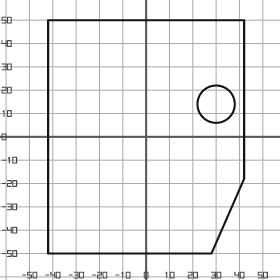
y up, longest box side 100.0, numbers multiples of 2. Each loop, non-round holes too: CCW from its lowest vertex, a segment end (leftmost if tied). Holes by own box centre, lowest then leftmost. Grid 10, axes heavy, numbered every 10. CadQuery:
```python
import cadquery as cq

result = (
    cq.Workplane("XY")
    .moveTo(-42.0, -50.0)
    .lineTo(28.0, -50.0)
    .lineTo(42.0, -18.0)
    .lineTo(42.0, 50.0)
    .lineTo(-42.0, 50.0)
    .close()
    .moveTo(30.0, 14.0)
    .circle(8.0)
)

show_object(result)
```